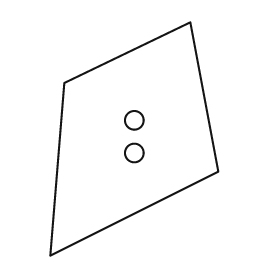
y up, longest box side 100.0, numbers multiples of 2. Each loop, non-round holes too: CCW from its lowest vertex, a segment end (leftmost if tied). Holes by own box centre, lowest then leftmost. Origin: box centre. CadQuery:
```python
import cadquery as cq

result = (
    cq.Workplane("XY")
    .moveTo(-36.0, -50.0)
    .lineTo(36.0, -14.0)
    .lineTo(24.0, 50.0)
    .lineTo(-30.0, 24.0)
    .close()
    .moveTo(0.0, -6.0)
    .circle(4.0)
    .moveTo(0.0, 8.0)
    .circle(4.0)
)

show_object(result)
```